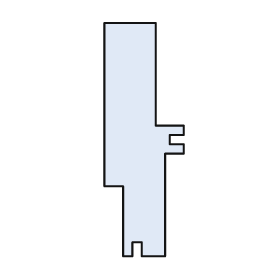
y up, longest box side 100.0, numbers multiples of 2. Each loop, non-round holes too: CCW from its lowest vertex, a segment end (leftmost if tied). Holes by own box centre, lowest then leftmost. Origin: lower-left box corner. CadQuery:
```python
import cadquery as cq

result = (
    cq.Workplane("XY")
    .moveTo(8.0, 0.0)
    .lineTo(12.0, 0.0)
    .lineTo(12.0, 6.0)
    .lineTo(16.0, 6.0)
    .lineTo(16.0, 0.0)
    .lineTo(26.0, 0.0)
    .lineTo(26.0, 44.0)
    .lineTo(34.0, 44.0)
    .lineTo(34.0, 48.0)
    .lineTo(28.0, 48.0)
    .lineTo(28.0, 52.0)
    .lineTo(34.0, 52.0)
    .lineTo(34.0, 56.0)
    .lineTo(22.0, 56.0)
    .lineTo(22.0, 100.0)
    .lineTo(0.0, 100.0)
    .lineTo(0.0, 30.0)
    .lineTo(8.0, 30.0)
    .close()
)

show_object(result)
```